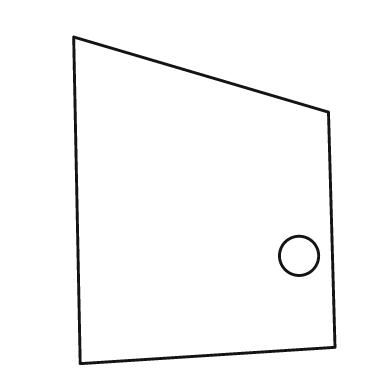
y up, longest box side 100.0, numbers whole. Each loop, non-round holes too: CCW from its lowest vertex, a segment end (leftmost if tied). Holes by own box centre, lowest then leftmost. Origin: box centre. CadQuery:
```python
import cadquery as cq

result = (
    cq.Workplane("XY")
    .moveTo(-38.0, -50.0)
    .lineTo(40.0, -45.0)
    .lineTo(38.0, 27.0)
    .lineTo(-40.0, 50.0)
    .close()
    .moveTo(29.0, -17.0)
    .circle(6.0)
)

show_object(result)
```